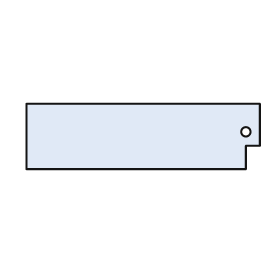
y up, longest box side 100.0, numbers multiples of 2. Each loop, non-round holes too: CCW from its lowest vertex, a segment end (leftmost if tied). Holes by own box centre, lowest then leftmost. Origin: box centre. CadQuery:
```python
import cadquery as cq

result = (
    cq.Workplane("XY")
    .moveTo(-50.0, -14.0)
    .lineTo(44.0, -14.0)
    .lineTo(44.0, -4.0)
    .lineTo(50.0, -4.0)
    .lineTo(50.0, 14.0)
    .lineTo(-50.0, 14.0)
    .close()
    .moveTo(44.0, 2.0)
    .circle(2.0)
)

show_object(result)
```